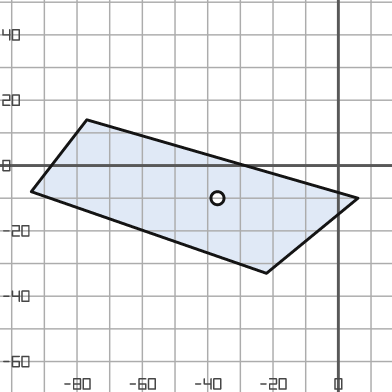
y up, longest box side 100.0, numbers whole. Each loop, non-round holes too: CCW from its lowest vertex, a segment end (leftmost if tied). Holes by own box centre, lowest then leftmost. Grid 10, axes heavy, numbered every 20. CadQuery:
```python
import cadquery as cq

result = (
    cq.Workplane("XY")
    .moveTo(-22.0, -33.0)
    .lineTo(6.0, -10.0)
    .lineTo(-77.0, 14.0)
    .lineTo(-94.0, -8.0)
    .close()
    .moveTo(-37.0, -10.0)
    .circle(2.0)
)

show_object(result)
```